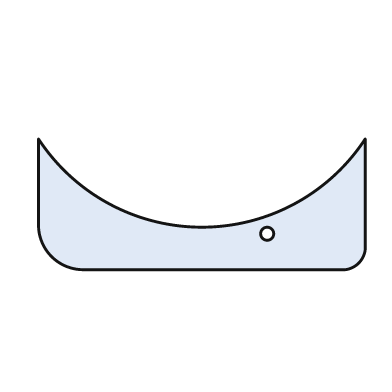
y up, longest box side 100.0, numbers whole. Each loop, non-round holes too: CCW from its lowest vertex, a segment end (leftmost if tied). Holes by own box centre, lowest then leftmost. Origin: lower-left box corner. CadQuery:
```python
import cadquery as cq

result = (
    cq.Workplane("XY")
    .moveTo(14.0, 0.0)
    .lineTo(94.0, 0.0)
    .threePointArc((98.0, 2.0), (100.0, 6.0))
    .lineTo(100.0, 40.0)
    .threePointArc((50.0, 13.0), (0.0, 40.0))
    .lineTo(0.0, 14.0)
    .threePointArc((4.0, 4.0), (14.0, 0.0))
    .close()
    .moveTo(70.0, 11.0)
    .circle(2.0)
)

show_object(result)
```